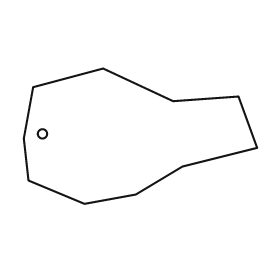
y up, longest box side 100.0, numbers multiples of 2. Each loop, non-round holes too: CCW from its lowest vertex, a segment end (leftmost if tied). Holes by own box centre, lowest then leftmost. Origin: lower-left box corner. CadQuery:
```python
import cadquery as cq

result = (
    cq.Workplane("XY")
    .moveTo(26.0, 0.0)
    .lineTo(48.0, 4.0)
    .lineTo(68.0, 16.0)
    .lineTo(100.0, 24.0)
    .lineTo(92.0, 46.0)
    .lineTo(64.0, 44.0)
    .lineTo(34.0, 58.0)
    .lineTo(4.0, 50.0)
    .lineTo(0.0, 28.0)
    .lineTo(2.0, 10.0)
    .close()
    .moveTo(8.0, 30.0)
    .circle(2.0)
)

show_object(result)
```